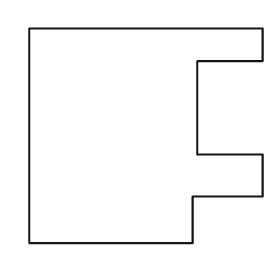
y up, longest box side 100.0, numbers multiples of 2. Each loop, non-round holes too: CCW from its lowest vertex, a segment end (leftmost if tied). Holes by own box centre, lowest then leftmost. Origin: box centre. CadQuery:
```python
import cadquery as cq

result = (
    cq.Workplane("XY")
    .moveTo(-50.0, -46.0)
    .lineTo(20.0, -46.0)
    .lineTo(20.0, -26.0)
    .lineTo(50.0, -26.0)
    .lineTo(50.0, -8.0)
    .lineTo(22.0, -8.0)
    .lineTo(22.0, 32.0)
    .lineTo(50.0, 32.0)
    .lineTo(50.0, 46.0)
    .lineTo(-50.0, 46.0)
    .close()
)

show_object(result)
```